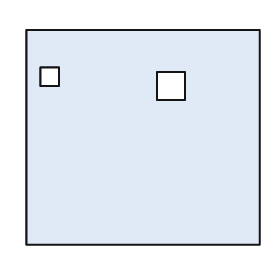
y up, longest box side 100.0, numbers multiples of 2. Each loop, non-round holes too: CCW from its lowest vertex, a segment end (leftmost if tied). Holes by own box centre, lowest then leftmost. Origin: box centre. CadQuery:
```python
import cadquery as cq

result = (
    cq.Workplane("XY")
    .moveTo(-50.0, -46.0)
    .lineTo(50.0, -46.0)
    .lineTo(50.0, 46.0)
    .lineTo(-50.0, 46.0)
    .close()
    .moveTo(6.0, 16.0)
    .lineTo(18.0, 16.0)
    .lineTo(18.0, 28.0)
    .lineTo(6.0, 28.0)
    .close()
    .moveTo(-44.0, 22.0)
    .lineTo(-36.0, 22.0)
    .lineTo(-36.0, 30.0)
    .lineTo(-44.0, 30.0)
    .close()
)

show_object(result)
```